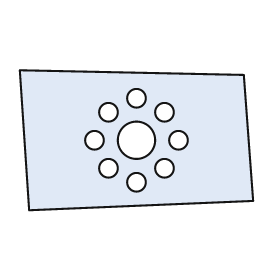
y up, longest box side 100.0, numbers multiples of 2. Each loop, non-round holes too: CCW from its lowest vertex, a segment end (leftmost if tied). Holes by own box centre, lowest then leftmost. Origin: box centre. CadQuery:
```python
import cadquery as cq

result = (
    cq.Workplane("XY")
    .moveTo(-46.0, -30.0)
    .lineTo(50.0, -26.0)
    .lineTo(46.0, 28.0)
    .lineTo(-50.0, 30.0)
    .close()
    .moveTo(0.0, -18.0)
    .circle(4.0)
    .moveTo(-12.0, -12.0)
    .circle(4.0)
    .moveTo(12.0, -12.0)
    .circle(4.0)
    .moveTo(-18.0, 0.0)
    .circle(4.0)
    .moveTo(0.0, 0.0)
    .circle(8.0)
    .moveTo(18.0, 0.0)
    .circle(4.0)
    .moveTo(-12.0, 12.0)
    .circle(4.0)
    .moveTo(12.0, 12.0)
    .circle(4.0)
    .moveTo(0.0, 18.0)
    .circle(4.0)
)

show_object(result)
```